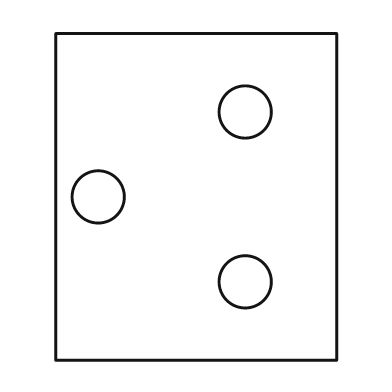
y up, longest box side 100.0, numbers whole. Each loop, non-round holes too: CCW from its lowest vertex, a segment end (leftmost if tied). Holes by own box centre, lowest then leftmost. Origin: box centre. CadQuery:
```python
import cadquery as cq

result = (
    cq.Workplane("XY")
    .moveTo(-43.0, -50.0)
    .lineTo(43.0, -50.0)
    .lineTo(43.0, 50.0)
    .lineTo(-43.0, 50.0)
    .close()
    .moveTo(15.0, -26.0)
    .circle(8.0)
    .moveTo(-30.0, 0.0)
    .circle(8.0)
    .moveTo(15.0, 26.0)
    .circle(8.0)
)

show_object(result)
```